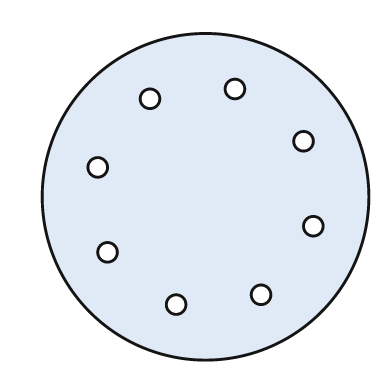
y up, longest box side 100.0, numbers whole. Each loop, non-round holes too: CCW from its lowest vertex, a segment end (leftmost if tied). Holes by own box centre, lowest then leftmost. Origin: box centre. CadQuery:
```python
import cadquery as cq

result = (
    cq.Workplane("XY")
    .moveTo(0.0, 0.0)
    .circle(50.0)
    .moveTo(-9.0, -33.0)
    .circle(3.0)
    .moveTo(17.0, -30.0)
    .circle(3.0)
    .moveTo(-30.0, -17.0)
    .circle(3.0)
    .moveTo(33.0, -9.0)
    .circle(3.0)
    .moveTo(-33.0, 9.0)
    .circle(3.0)
    .moveTo(30.0, 17.0)
    .circle(3.0)
    .moveTo(-17.0, 30.0)
    .circle(3.0)
    .moveTo(9.0, 33.0)
    .circle(3.0)
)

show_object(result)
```